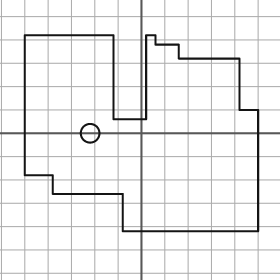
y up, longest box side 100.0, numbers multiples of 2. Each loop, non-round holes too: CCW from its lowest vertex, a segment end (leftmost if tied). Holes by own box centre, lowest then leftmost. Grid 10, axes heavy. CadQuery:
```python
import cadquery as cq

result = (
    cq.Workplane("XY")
    .moveTo(-8.0, -42.0)
    .lineTo(50.0, -42.0)
    .lineTo(50.0, 10.0)
    .lineTo(42.0, 10.0)
    .lineTo(42.0, 32.0)
    .lineTo(16.0, 32.0)
    .lineTo(16.0, 38.0)
    .lineTo(6.0, 38.0)
    .lineTo(6.0, 42.0)
    .lineTo(2.0, 42.0)
    .lineTo(2.0, 6.0)
    .lineTo(-12.0, 6.0)
    .lineTo(-12.0, 42.0)
    .lineTo(-50.0, 42.0)
    .lineTo(-50.0, -18.0)
    .lineTo(-38.0, -18.0)
    .lineTo(-38.0, -26.0)
    .lineTo(-8.0, -26.0)
    .close()
    .moveTo(-22.0, 0.0)
    .circle(4.0)
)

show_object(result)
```